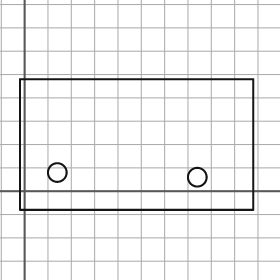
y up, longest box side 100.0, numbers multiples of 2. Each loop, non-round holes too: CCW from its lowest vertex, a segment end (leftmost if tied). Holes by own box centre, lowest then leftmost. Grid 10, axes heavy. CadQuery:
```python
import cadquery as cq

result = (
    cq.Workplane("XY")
    .moveTo(-2.0, -8.0)
    .lineTo(98.0, -8.0)
    .lineTo(98.0, 48.0)
    .lineTo(-2.0, 48.0)
    .close()
    .moveTo(74.0, 6.0)
    .circle(4.0)
    .moveTo(14.0, 8.0)
    .circle(4.0)
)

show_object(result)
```